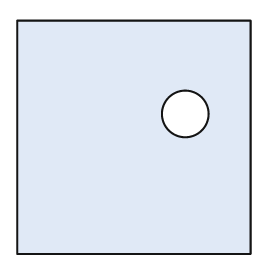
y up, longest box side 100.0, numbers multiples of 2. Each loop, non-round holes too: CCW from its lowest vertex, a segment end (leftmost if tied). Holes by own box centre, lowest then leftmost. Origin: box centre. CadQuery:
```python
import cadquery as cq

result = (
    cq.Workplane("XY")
    .moveTo(-50.0, -50.0)
    .lineTo(50.0, -50.0)
    .lineTo(50.0, 50.0)
    .lineTo(-50.0, 50.0)
    .close()
    .moveTo(22.0, 10.0)
    .circle(10.0)
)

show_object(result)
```